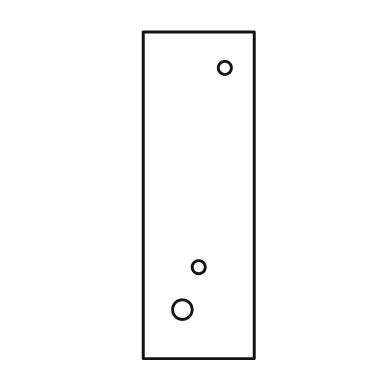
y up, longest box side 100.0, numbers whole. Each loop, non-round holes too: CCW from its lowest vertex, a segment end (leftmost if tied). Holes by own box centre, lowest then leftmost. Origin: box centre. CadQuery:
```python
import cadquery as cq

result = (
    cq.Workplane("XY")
    .moveTo(-17.0, -50.0)
    .lineTo(17.0, -50.0)
    .lineTo(17.0, 50.0)
    .lineTo(-17.0, 50.0)
    .close()
    .moveTo(-5.0, -35.0)
    .circle(3.0)
    .moveTo(0.0, -22.0)
    .circle(2.0)
    .moveTo(8.0, 39.0)
    .circle(2.0)
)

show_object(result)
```